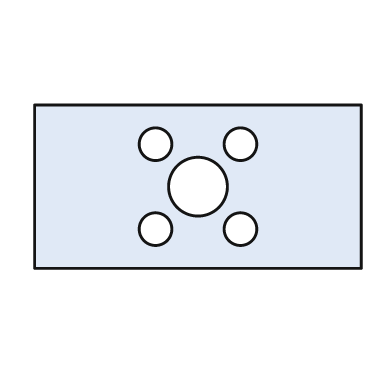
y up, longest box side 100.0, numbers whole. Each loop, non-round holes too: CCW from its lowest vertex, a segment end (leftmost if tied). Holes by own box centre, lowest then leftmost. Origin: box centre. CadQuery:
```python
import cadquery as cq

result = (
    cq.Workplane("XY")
    .moveTo(-50.0, -25.0)
    .lineTo(50.0, -25.0)
    .lineTo(50.0, 25.0)
    .lineTo(-50.0, 25.0)
    .close()
    .moveTo(-13.0, -13.0)
    .circle(5.0)
    .moveTo(13.0, -13.0)
    .circle(5.0)
    .moveTo(0.0, 0.0)
    .circle(9.0)
    .moveTo(-13.0, 13.0)
    .circle(5.0)
    .moveTo(13.0, 13.0)
    .circle(5.0)
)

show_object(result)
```